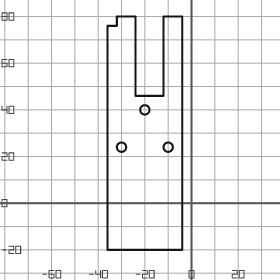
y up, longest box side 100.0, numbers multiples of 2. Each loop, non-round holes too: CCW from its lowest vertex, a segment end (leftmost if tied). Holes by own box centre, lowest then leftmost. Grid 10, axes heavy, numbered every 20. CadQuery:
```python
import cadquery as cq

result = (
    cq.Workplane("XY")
    .moveTo(-36.0, -20.0)
    .lineTo(-4.0, -20.0)
    .lineTo(-4.0, 80.0)
    .lineTo(-12.0, 80.0)
    .lineTo(-12.0, 46.0)
    .lineTo(-24.0, 46.0)
    .lineTo(-24.0, 80.0)
    .lineTo(-32.0, 80.0)
    .lineTo(-32.0, 76.0)
    .lineTo(-36.0, 76.0)
    .close()
    .moveTo(-30.0, 24.0)
    .circle(2.0)
    .moveTo(-10.0, 24.0)
    .circle(2.0)
    .moveTo(-20.0, 40.0)
    .circle(2.0)
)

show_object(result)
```